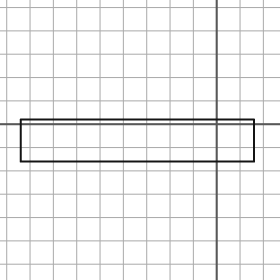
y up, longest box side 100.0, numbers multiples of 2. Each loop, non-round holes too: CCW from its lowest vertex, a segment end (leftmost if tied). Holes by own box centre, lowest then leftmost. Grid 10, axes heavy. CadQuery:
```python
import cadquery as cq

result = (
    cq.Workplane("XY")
    .moveTo(-84.0, -16.0)
    .lineTo(16.0, -16.0)
    .lineTo(16.0, 2.0)
    .lineTo(-84.0, 2.0)
    .close()
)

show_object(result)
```